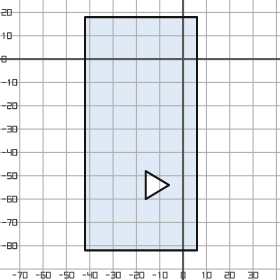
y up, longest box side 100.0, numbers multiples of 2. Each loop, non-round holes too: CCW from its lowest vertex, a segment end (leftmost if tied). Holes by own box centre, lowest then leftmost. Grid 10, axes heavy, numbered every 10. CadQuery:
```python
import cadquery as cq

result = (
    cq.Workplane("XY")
    .moveTo(-42.0, -82.0)
    .lineTo(6.0, -82.0)
    .lineTo(6.0, 18.0)
    .lineTo(-42.0, 18.0)
    .close()
    .moveTo(-16.0, -60.0)
    .lineTo(-6.0, -54.0)
    .lineTo(-16.0, -48.0)
    .close()
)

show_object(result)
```